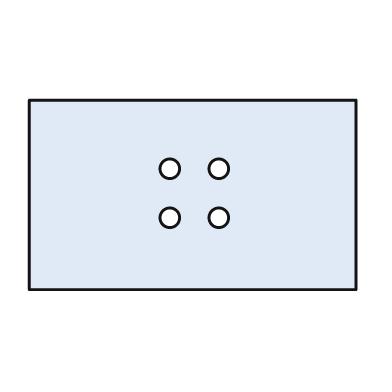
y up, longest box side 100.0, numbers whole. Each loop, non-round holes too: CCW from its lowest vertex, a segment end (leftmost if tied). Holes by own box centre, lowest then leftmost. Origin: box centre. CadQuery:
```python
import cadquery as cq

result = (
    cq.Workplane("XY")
    .moveTo(-50.0, -29.0)
    .lineTo(50.0, -29.0)
    .lineTo(50.0, 29.0)
    .lineTo(-50.0, 29.0)
    .close()
    .moveTo(-7.0, -7.0)
    .circle(3.0)
    .moveTo(8.0, -7.0)
    .circle(3.0)
    .moveTo(-7.0, 8.0)
    .circle(3.0)
    .moveTo(8.0, 8.0)
    .circle(3.0)
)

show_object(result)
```